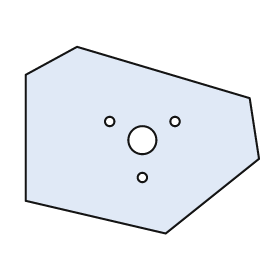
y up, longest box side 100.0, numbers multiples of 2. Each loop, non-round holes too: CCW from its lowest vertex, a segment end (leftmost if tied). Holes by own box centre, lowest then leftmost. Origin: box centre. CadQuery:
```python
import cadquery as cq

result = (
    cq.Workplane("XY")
    .moveTo(10.0, -40.0)
    .lineTo(50.0, -8.0)
    .lineTo(46.0, 18.0)
    .lineTo(-28.0, 40.0)
    .lineTo(-50.0, 28.0)
    .lineTo(-50.0, -26.0)
    .close()
    .moveTo(0.0, -16.0)
    .circle(2.0)
    .moveTo(0.0, 0.0)
    .circle(6.0)
    .moveTo(-14.0, 8.0)
    .circle(2.0)
    .moveTo(14.0, 8.0)
    .circle(2.0)
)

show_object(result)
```